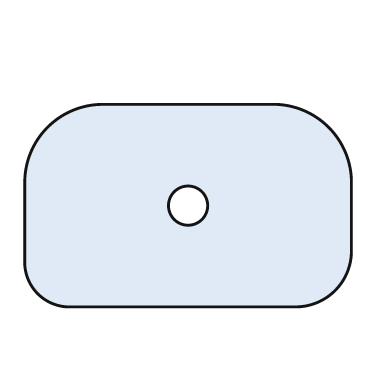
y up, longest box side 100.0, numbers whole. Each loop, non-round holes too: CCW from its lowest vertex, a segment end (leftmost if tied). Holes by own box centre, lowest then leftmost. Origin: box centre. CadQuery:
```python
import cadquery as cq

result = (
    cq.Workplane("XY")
    .moveTo(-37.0, -31.0)
    .lineTo(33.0, -31.0)
    .threePointArc((45.0, -26.0), (50.0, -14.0))
    .lineTo(50.0, 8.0)
    .threePointArc((43.0, 24.0), (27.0, 31.0))
    .lineTo(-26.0, 31.0)
    .threePointArc((-43.0, 24.0), (-50.0, 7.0))
    .lineTo(-50.0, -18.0)
    .threePointArc((-46.0, -27.0), (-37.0, -31.0))
    .close()
    .moveTo(0.0, 0.0)
    .circle(6.0)
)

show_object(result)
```